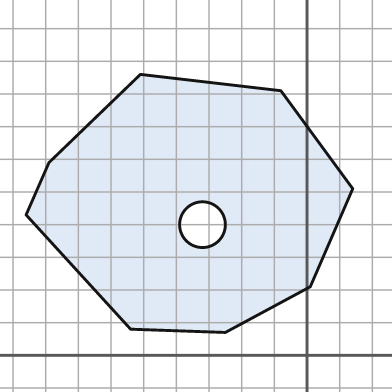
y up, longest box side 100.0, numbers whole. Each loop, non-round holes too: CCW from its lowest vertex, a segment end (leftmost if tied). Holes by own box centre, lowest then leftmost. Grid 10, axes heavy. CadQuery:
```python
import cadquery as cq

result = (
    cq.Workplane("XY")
    .moveTo(-25.0, 7.0)
    .lineTo(1.0, 21.0)
    .lineTo(14.0, 51.0)
    .lineTo(-8.0, 81.0)
    .lineTo(-51.0, 86.0)
    .lineTo(-79.0, 59.0)
    .lineTo(-86.0, 43.0)
    .lineTo(-54.0, 8.0)
    .close()
    .moveTo(-32.0, 40.0)
    .circle(7.0)
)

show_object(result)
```